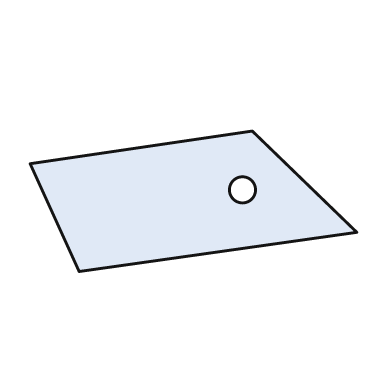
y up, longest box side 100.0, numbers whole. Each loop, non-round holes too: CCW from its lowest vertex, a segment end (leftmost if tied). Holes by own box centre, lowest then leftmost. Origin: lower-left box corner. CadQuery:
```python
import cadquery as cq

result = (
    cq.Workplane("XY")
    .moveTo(15.0, 0.0)
    .lineTo(100.0, 12.0)
    .lineTo(68.0, 43.0)
    .lineTo(0.0, 33.0)
    .close()
    .moveTo(65.0, 25.0)
    .circle(4.0)
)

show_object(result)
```